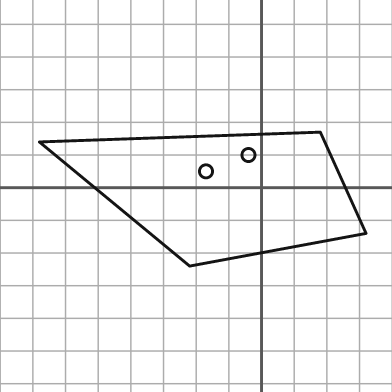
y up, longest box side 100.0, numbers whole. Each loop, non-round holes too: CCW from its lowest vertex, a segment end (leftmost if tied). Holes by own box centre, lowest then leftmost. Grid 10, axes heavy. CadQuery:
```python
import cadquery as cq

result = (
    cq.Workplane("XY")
    .moveTo(-22.0, -24.0)
    .lineTo(32.0, -14.0)
    .lineTo(18.0, 17.0)
    .lineTo(-68.0, 14.0)
    .close()
    .moveTo(-17.0, 5.0)
    .circle(2.0)
    .moveTo(-4.0, 10.0)
    .circle(2.0)
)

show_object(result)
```